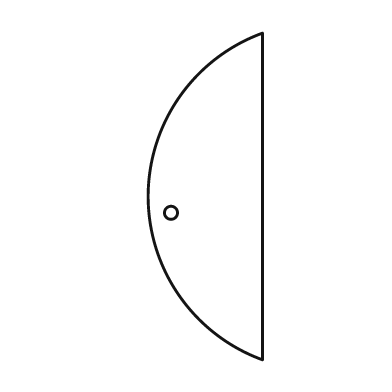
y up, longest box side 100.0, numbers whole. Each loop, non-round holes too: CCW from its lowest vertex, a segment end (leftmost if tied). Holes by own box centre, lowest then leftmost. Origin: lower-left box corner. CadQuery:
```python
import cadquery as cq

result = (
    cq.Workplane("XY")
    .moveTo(35.0, 0.0)
    .lineTo(35.0, 100.0)
    .threePointArc((0.0, 50.0), (35.0, 0.0))
    .close()
    .moveTo(7.0, 45.0)
    .circle(2.0)
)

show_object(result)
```